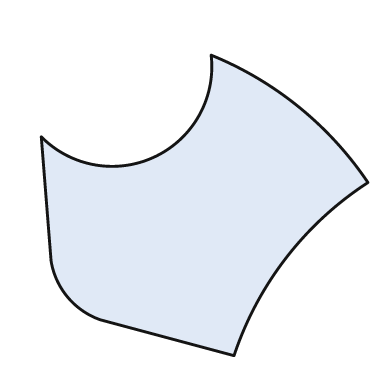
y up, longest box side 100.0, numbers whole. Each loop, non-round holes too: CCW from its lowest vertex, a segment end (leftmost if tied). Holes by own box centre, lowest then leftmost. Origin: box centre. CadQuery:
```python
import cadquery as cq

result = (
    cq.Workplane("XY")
    .moveTo(9.0, -46.0)
    .threePointArc((25.0, -16.0), (50.0, 7.0))
    .threePointArc((29.0, 30.0), (2.0, 46.0))
    .threePointArc((-15.0, 15.0), (-50.0, 21.0))
    .lineTo(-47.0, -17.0)
    .threePointArc((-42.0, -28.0), (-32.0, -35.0))
    .close()
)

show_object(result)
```